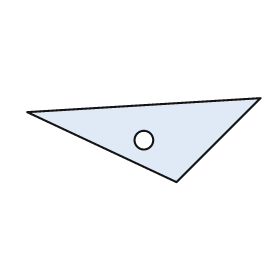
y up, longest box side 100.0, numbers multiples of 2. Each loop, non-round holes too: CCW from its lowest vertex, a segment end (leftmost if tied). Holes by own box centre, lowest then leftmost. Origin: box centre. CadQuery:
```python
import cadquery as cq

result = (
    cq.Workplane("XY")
    .moveTo(14.0, -18.0)
    .lineTo(50.0, 18.0)
    .lineTo(-50.0, 12.0)
    .close()
    .moveTo(0.0, 0.0)
    .circle(4.0)
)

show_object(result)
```